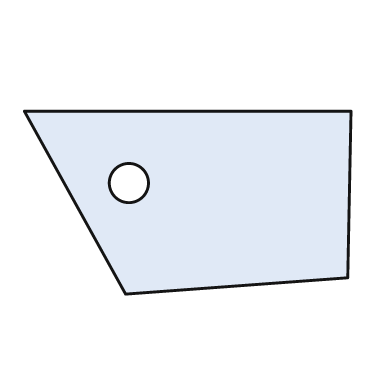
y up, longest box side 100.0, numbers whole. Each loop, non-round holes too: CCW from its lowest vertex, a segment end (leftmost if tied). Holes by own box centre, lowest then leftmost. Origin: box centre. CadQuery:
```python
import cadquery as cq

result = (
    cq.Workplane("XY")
    .moveTo(-19.0, -28.0)
    .lineTo(49.0, -23.0)
    .lineTo(50.0, 28.0)
    .lineTo(-50.0, 28.0)
    .close()
    .moveTo(-18.0, 6.0)
    .circle(6.0)
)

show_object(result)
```